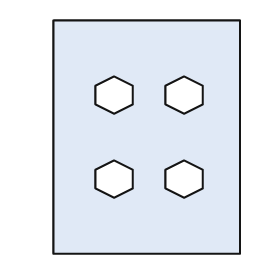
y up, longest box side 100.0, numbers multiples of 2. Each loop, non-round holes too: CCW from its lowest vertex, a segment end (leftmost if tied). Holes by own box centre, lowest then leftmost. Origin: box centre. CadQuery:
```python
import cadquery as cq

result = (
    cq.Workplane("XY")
    .moveTo(-40.0, -50.0)
    .lineTo(40.0, -50.0)
    .lineTo(40.0, 50.0)
    .lineTo(-40.0, 50.0)
    .close()
    .moveTo(-14.0, -26.0)
    .lineTo(-6.0, -22.0)
    .lineTo(-6.0, -14.0)
    .lineTo(-14.0, -10.0)
    .lineTo(-22.0, -14.0)
    .lineTo(-22.0, -22.0)
    .close()
    .moveTo(16.0, -26.0)
    .lineTo(24.0, -22.0)
    .lineTo(24.0, -14.0)
    .lineTo(16.0, -10.0)
    .lineTo(8.0, -14.0)
    .lineTo(8.0, -22.0)
    .close()
    .moveTo(-14.0, 10.0)
    .lineTo(-6.0, 14.0)
    .lineTo(-6.0, 22.0)
    .lineTo(-14.0, 26.0)
    .lineTo(-22.0, 22.0)
    .lineTo(-22.0, 14.0)
    .close()
    .moveTo(16.0, 10.0)
    .lineTo(24.0, 14.0)
    .lineTo(24.0, 22.0)
    .lineTo(16.0, 26.0)
    .lineTo(8.0, 22.0)
    .lineTo(8.0, 14.0)
    .close()
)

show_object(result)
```